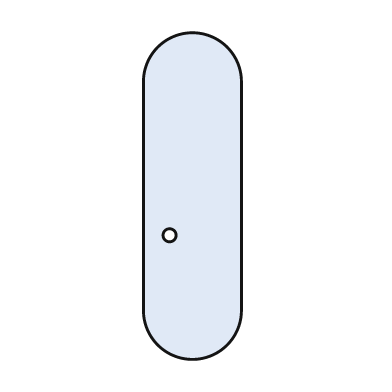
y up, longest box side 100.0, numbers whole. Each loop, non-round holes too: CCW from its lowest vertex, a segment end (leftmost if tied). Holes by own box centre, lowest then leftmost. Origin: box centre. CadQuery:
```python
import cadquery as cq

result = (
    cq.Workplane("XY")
    .moveTo(-15.0, -35.0)
    .threePointArc((0.0, -50.0), (15.0, -35.0))
    .lineTo(15.0, 35.0)
    .threePointArc((0.0, 50.0), (-15.0, 35.0))
    .close()
    .moveTo(-7.0, -12.0)
    .circle(2.0)
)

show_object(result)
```